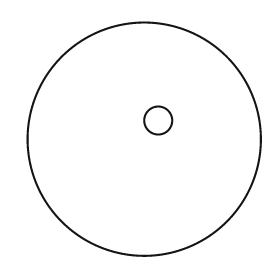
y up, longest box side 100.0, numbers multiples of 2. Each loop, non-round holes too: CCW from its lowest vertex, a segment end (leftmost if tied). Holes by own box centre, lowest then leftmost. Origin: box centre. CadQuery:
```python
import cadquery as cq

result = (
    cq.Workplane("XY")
    .moveTo(0.0, 0.0)
    .circle(50.0)
    .moveTo(6.0, 8.0)
    .circle(6.0)
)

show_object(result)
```